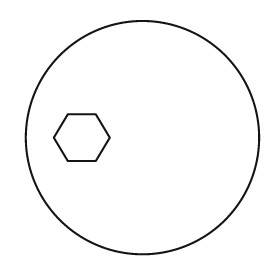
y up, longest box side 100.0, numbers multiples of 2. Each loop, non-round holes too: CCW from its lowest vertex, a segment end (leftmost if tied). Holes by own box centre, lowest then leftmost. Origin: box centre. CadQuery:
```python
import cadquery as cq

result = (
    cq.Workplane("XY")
    .moveTo(0.0, 0.0)
    .circle(50.0)
    .moveTo(-32.0, -10.0)
    .lineTo(-20.0, -10.0)
    .lineTo(-14.0, 0.0)
    .lineTo(-20.0, 10.0)
    .lineTo(-32.0, 10.0)
    .lineTo(-38.0, 0.0)
    .close()
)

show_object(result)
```